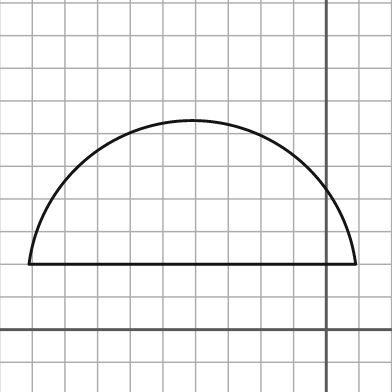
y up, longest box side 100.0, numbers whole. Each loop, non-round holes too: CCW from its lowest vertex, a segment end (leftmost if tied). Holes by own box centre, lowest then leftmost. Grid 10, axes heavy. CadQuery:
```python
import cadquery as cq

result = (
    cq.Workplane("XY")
    .moveTo(-91.0, 20.0)
    .lineTo(9.0, 20.0)
    .threePointArc((-41.0, 64.0), (-91.0, 20.0))
    .close()
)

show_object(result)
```